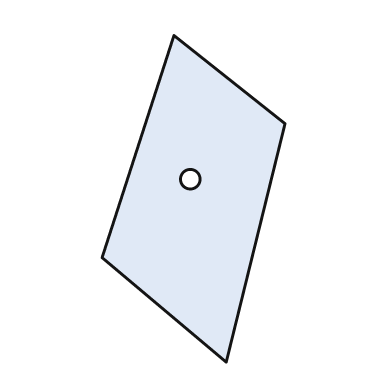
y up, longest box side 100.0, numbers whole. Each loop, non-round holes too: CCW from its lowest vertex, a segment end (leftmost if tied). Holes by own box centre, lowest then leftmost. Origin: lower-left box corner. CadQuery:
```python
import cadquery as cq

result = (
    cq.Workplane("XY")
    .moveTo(38.0, 0.0)
    .lineTo(56.0, 73.0)
    .lineTo(22.0, 100.0)
    .lineTo(0.0, 32.0)
    .close()
    .moveTo(27.0, 56.0)
    .circle(3.0)
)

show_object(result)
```